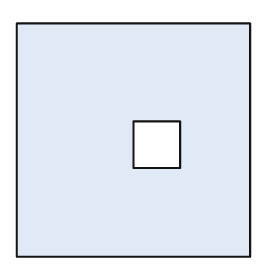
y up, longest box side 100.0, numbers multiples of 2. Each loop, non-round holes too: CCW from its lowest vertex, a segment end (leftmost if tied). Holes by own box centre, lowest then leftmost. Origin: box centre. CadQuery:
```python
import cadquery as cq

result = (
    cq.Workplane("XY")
    .moveTo(-50.0, -50.0)
    .lineTo(50.0, -50.0)
    .lineTo(50.0, 50.0)
    .lineTo(-50.0, 50.0)
    .close()
    .moveTo(0.0, -12.0)
    .lineTo(20.0, -12.0)
    .lineTo(20.0, 8.0)
    .lineTo(0.0, 8.0)
    .close()
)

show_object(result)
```